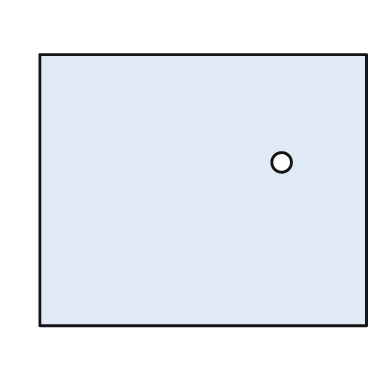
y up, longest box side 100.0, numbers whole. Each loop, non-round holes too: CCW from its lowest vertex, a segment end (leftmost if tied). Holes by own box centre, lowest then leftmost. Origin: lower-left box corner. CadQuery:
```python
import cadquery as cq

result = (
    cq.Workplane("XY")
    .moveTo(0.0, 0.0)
    .lineTo(100.0, 0.0)
    .lineTo(100.0, 83.0)
    .lineTo(0.0, 83.0)
    .close()
    .moveTo(74.0, 50.0)
    .circle(3.0)
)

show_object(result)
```